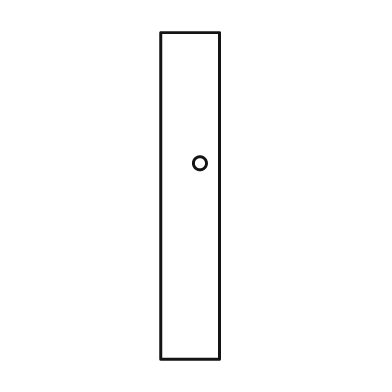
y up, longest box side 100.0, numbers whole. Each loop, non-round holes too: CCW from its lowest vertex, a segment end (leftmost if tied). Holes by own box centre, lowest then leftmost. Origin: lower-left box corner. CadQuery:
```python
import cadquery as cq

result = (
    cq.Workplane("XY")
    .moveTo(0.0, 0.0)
    .lineTo(18.0, 0.0)
    .lineTo(18.0, 100.0)
    .lineTo(0.0, 100.0)
    .close()
    .moveTo(12.0, 60.0)
    .circle(2.0)
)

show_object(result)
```